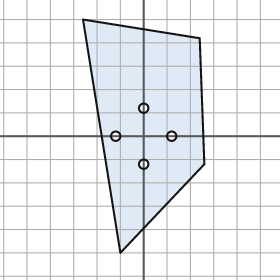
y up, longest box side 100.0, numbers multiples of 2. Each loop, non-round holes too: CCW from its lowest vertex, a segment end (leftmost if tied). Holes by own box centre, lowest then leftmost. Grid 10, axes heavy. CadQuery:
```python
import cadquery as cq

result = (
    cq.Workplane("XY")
    .moveTo(-10.0, -50.0)
    .lineTo(26.0, -12.0)
    .lineTo(24.0, 42.0)
    .lineTo(-26.0, 50.0)
    .close()
    .moveTo(0.0, -12.0)
    .circle(2.0)
    .moveTo(-12.0, 0.0)
    .circle(2.0)
    .moveTo(12.0, 0.0)
    .circle(2.0)
    .moveTo(0.0, 12.0)
    .circle(2.0)
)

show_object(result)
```